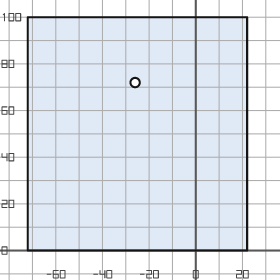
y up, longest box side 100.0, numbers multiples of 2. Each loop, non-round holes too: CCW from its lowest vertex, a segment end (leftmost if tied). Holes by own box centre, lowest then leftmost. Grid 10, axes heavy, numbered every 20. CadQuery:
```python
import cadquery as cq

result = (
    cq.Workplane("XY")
    .moveTo(-72.0, 0.0)
    .lineTo(22.0, 0.0)
    .lineTo(22.0, 100.0)
    .lineTo(-72.0, 100.0)
    .close()
    .moveTo(-26.0, 72.0)
    .circle(2.0)
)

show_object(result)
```